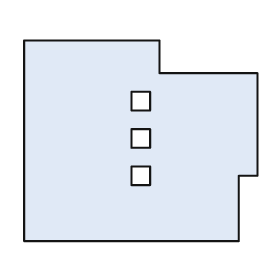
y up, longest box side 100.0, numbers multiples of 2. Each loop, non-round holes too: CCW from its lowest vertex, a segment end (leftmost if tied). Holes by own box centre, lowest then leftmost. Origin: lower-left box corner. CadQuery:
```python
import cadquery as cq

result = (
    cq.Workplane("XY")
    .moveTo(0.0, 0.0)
    .lineTo(92.0, 0.0)
    .lineTo(92.0, 28.0)
    .lineTo(100.0, 28.0)
    .lineTo(100.0, 72.0)
    .lineTo(58.0, 72.0)
    .lineTo(58.0, 86.0)
    .lineTo(0.0, 86.0)
    .close()
    .moveTo(46.0, 24.0)
    .lineTo(54.0, 24.0)
    .lineTo(54.0, 32.0)
    .lineTo(46.0, 32.0)
    .close()
    .moveTo(46.0, 40.0)
    .lineTo(54.0, 40.0)
    .lineTo(54.0, 48.0)
    .lineTo(46.0, 48.0)
    .close()
    .moveTo(46.0, 56.0)
    .lineTo(54.0, 56.0)
    .lineTo(54.0, 64.0)
    .lineTo(46.0, 64.0)
    .close()
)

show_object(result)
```